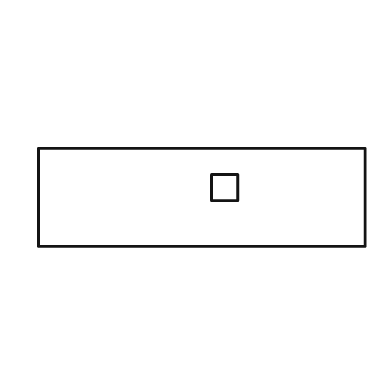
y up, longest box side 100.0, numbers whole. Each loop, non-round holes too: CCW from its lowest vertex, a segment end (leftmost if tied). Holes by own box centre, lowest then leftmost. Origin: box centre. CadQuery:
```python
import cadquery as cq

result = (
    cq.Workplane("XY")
    .moveTo(-50.0, -15.0)
    .lineTo(50.0, -15.0)
    .lineTo(50.0, 15.0)
    .lineTo(-50.0, 15.0)
    .close()
    .moveTo(3.0, -1.0)
    .lineTo(11.0, -1.0)
    .lineTo(11.0, 7.0)
    .lineTo(3.0, 7.0)
    .close()
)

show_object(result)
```